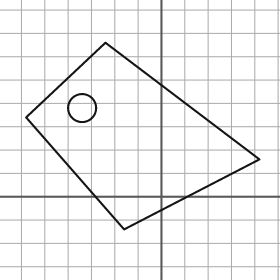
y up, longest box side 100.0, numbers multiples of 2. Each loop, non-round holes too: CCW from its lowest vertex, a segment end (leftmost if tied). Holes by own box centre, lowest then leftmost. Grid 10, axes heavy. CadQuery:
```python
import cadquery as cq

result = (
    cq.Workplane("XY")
    .moveTo(-16.0, -14.0)
    .lineTo(42.0, 16.0)
    .lineTo(-24.0, 66.0)
    .lineTo(-58.0, 34.0)
    .close()
    .moveTo(-34.0, 38.0)
    .circle(6.0)
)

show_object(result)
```